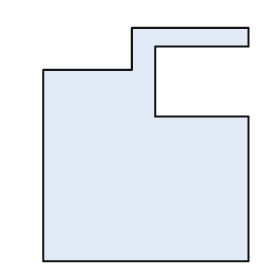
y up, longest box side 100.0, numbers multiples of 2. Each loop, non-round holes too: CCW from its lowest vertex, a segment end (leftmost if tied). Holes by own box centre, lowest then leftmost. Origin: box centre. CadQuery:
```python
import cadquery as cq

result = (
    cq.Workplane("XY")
    .moveTo(-44.0, -50.0)
    .lineTo(44.0, -50.0)
    .lineTo(44.0, 12.0)
    .lineTo(4.0, 12.0)
    .lineTo(4.0, 42.0)
    .lineTo(44.0, 42.0)
    .lineTo(44.0, 50.0)
    .lineTo(-6.0, 50.0)
    .lineTo(-6.0, 32.0)
    .lineTo(-44.0, 32.0)
    .close()
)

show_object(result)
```